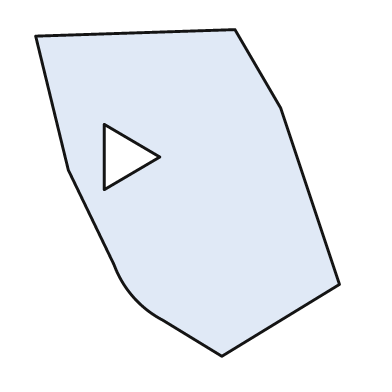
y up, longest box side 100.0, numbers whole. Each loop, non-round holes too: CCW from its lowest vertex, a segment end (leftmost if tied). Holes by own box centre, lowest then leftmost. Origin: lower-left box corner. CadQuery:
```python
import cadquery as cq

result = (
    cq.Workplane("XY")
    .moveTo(57.0, 0.0)
    .lineTo(93.0, 22.0)
    .lineTo(75.0, 76.0)
    .lineTo(61.0, 100.0)
    .lineTo(0.0, 98.0)
    .lineTo(10.0, 57.0)
    .lineTo(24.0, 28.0)
    .threePointArc((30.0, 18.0), (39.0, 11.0))
    .close()
    .moveTo(21.0, 51.0)
    .lineTo(38.0, 61.0)
    .lineTo(21.0, 71.0)
    .close()
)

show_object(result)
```